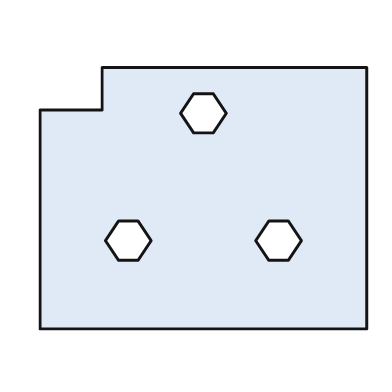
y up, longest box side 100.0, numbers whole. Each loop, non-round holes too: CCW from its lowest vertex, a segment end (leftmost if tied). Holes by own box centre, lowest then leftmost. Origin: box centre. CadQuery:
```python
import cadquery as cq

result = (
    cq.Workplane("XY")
    .moveTo(-50.0, -40.0)
    .lineTo(50.0, -40.0)
    .lineTo(50.0, 40.0)
    .lineTo(-31.0, 40.0)
    .lineTo(-31.0, 27.0)
    .lineTo(-50.0, 27.0)
    .close()
    .moveTo(-26.0, -19.0)
    .lineTo(-20.0, -19.0)
    .lineTo(-16.0, -13.0)
    .lineTo(-20.0, -7.0)
    .lineTo(-26.0, -7.0)
    .lineTo(-30.0, -13.0)
    .close()
    .moveTo(20.0, -19.0)
    .lineTo(26.0, -19.0)
    .lineTo(30.0, -13.0)
    .lineTo(26.0, -7.0)
    .lineTo(20.0, -7.0)
    .lineTo(16.0, -13.0)
    .close()
    .moveTo(-3.0, 20.0)
    .lineTo(3.0, 20.0)
    .lineTo(7.0, 26.0)
    .lineTo(3.0, 32.0)
    .lineTo(-3.0, 32.0)
    .lineTo(-7.0, 26.0)
    .close()
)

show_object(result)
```